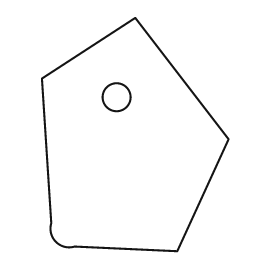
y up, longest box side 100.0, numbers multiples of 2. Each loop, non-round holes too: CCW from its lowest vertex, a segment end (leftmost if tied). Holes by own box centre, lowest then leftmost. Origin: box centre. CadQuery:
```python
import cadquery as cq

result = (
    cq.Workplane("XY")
    .moveTo(18.0, -50.0)
    .lineTo(40.0, -2.0)
    .lineTo(0.0, 50.0)
    .lineTo(-40.0, 24.0)
    .lineTo(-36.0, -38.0)
    .threePointArc((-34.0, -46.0), (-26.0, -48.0))
    .close()
    .moveTo(-8.0, 16.0)
    .circle(6.0)
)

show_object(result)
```